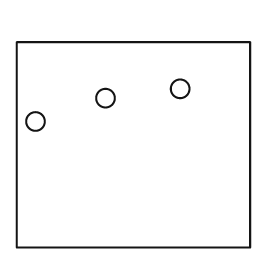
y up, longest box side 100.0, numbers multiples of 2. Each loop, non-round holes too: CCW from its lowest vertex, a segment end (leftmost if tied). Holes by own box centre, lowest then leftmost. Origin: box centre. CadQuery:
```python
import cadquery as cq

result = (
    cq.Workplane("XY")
    .moveTo(-50.0, -44.0)
    .lineTo(50.0, -44.0)
    .lineTo(50.0, 44.0)
    .lineTo(-50.0, 44.0)
    .close()
    .moveTo(-42.0, 10.0)
    .circle(4.0)
    .moveTo(-12.0, 20.0)
    .circle(4.0)
    .moveTo(20.0, 24.0)
    .circle(4.0)
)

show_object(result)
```